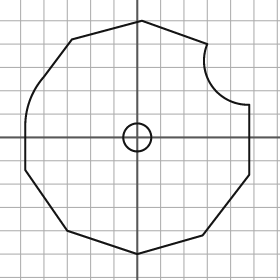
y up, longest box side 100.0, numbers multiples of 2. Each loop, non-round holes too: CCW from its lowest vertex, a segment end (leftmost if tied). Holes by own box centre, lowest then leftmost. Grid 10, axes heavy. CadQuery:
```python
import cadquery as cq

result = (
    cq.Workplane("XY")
    .moveTo(0.0, -50.0)
    .lineTo(28.0, -42.0)
    .lineTo(48.0, -16.0)
    .lineTo(48.0, 14.0)
    .threePointArc((32.0, 22.0), (30.0, 40.0))
    .lineTo(2.0, 50.0)
    .lineTo(-28.0, 42.0)
    .lineTo(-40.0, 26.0)
    .threePointArc((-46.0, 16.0), (-48.0, 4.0))
    .lineTo(-48.0, -14.0)
    .lineTo(-30.0, -40.0)
    .close()
    .moveTo(0.0, 0.0)
    .circle(6.0)
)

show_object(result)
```